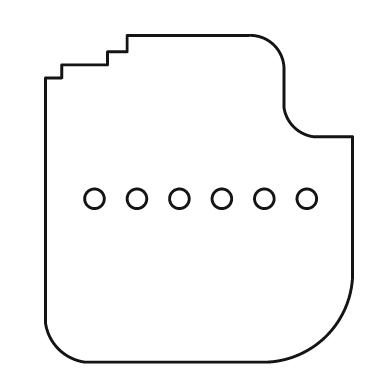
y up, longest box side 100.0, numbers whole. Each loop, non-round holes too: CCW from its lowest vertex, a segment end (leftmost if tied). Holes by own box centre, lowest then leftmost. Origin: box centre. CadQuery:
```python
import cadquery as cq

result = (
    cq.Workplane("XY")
    .moveTo(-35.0, -50.0)
    .lineTo(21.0, -50.0)
    .threePointArc((39.0, -42.0), (47.0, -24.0))
    .lineTo(47.0, 19.0)
    .lineTo(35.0, 19.0)
    .threePointArc((29.0, 22.0), (26.0, 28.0))
    .lineTo(26.0, 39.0)
    .threePointArc((23.0, 47.0), (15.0, 50.0))
    .lineTo(-22.0, 50.0)
    .lineTo(-22.0, 45.0)
    .lineTo(-28.0, 45.0)
    .lineTo(-28.0, 41.0)
    .lineTo(-42.0, 41.0)
    .lineTo(-42.0, 37.0)
    .lineTo(-47.0, 37.0)
    .lineTo(-47.0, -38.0)
    .threePointArc((-43.0, -46.0), (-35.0, -50.0))
    .close()
    .moveTo(-32.0, 0.0)
    .circle(3.0)
    .moveTo(-19.0, 0.0)
    .circle(3.0)
    .moveTo(-6.0, 0.0)
    .circle(3.0)
    .moveTo(7.0, 0.0)
    .circle(3.0)
    .moveTo(20.0, 0.0)
    .circle(3.0)
    .moveTo(33.0, 0.0)
    .circle(3.0)
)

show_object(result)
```